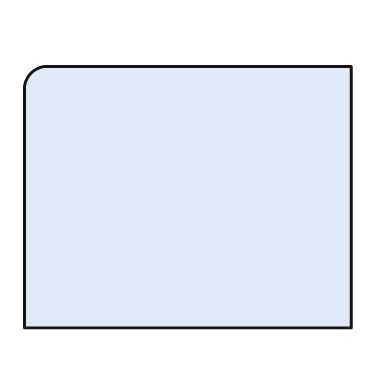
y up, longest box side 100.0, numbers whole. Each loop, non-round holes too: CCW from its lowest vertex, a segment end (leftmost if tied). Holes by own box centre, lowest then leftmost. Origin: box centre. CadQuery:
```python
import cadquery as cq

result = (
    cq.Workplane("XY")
    .moveTo(-50.0, -40.0)
    .lineTo(50.0, -40.0)
    .lineTo(50.0, 40.0)
    .lineTo(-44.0, 40.0)
    .threePointArc((-48.0, 38.0), (-50.0, 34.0))
    .close()
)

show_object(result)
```